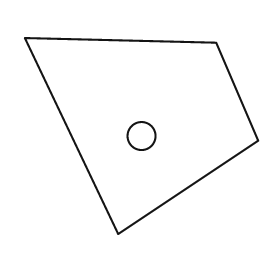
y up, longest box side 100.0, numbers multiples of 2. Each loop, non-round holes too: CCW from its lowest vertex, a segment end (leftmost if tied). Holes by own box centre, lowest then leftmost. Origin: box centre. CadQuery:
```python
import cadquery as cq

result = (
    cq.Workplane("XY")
    .moveTo(-10.0, -42.0)
    .lineTo(50.0, -2.0)
    .lineTo(32.0, 40.0)
    .lineTo(-50.0, 42.0)
    .close()
    .moveTo(0.0, 0.0)
    .circle(6.0)
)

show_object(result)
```